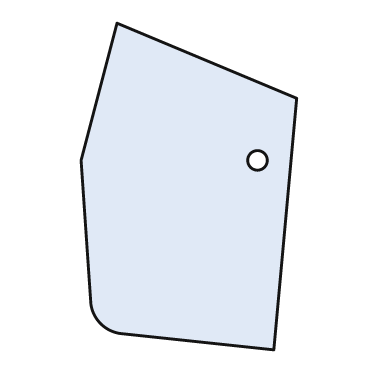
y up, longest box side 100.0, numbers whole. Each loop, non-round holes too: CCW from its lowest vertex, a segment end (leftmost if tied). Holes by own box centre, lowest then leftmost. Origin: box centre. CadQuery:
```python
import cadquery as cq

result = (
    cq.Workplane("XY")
    .moveTo(26.0, -50.0)
    .lineTo(33.0, 27.0)
    .lineTo(-22.0, 50.0)
    .lineTo(-33.0, 8.0)
    .lineTo(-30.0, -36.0)
    .threePointArc((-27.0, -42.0), (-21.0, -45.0))
    .close()
    .moveTo(21.0, 8.0)
    .circle(3.0)
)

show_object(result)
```